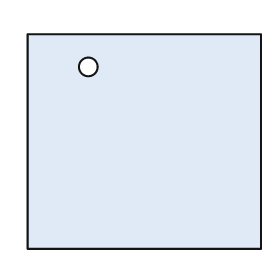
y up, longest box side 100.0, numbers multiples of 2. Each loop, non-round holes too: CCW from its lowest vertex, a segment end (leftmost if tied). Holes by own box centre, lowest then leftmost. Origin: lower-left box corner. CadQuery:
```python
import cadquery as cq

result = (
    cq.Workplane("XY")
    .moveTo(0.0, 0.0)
    .lineTo(100.0, 0.0)
    .lineTo(100.0, 92.0)
    .lineTo(0.0, 92.0)
    .close()
    .moveTo(26.0, 78.0)
    .circle(4.0)
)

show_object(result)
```